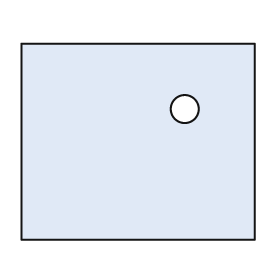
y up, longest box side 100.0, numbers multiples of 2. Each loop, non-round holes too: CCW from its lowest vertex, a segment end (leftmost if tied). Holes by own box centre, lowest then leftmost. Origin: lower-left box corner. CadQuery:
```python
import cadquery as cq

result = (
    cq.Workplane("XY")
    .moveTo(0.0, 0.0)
    .lineTo(100.0, 0.0)
    .lineTo(100.0, 84.0)
    .lineTo(0.0, 84.0)
    .close()
    .moveTo(70.0, 56.0)
    .circle(6.0)
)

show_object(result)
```